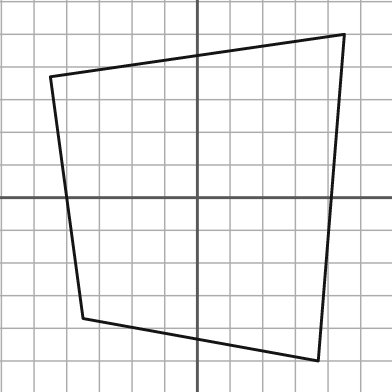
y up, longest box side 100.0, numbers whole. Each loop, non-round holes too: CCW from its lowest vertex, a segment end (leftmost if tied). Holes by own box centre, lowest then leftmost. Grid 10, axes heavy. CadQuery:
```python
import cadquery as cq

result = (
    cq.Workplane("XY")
    .moveTo(37.0, -50.0)
    .lineTo(45.0, 50.0)
    .lineTo(-45.0, 37.0)
    .lineTo(-35.0, -37.0)
    .close()
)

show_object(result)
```